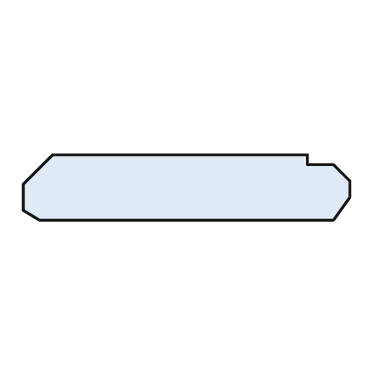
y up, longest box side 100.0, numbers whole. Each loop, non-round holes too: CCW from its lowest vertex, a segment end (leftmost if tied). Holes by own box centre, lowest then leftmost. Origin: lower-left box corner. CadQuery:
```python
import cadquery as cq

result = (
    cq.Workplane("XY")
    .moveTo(5.0, 0.0)
    .lineTo(95.0, 0.0)
    .lineTo(100.0, 7.0)
    .lineTo(100.0, 12.0)
    .lineTo(95.0, 17.0)
    .lineTo(87.0, 17.0)
    .lineTo(87.0, 20.0)
    .lineTo(9.0, 20.0)
    .lineTo(0.0, 11.0)
    .lineTo(0.0, 3.0)
    .close()
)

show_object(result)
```